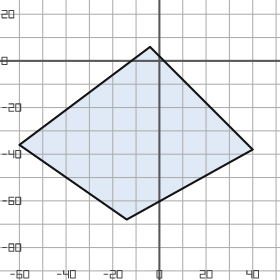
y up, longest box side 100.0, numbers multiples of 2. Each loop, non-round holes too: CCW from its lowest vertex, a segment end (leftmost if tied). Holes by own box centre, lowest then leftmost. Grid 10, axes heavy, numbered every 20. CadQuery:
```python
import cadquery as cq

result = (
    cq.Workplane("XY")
    .moveTo(-14.0, -68.0)
    .lineTo(40.0, -38.0)
    .lineTo(-4.0, 6.0)
    .lineTo(-60.0, -36.0)
    .close()
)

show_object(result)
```